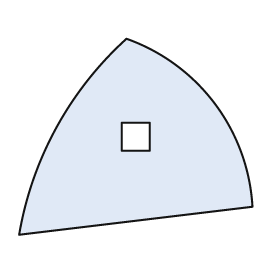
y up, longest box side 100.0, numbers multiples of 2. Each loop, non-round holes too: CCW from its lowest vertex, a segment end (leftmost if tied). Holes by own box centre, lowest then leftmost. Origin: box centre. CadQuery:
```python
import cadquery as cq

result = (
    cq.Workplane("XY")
    .moveTo(-50.0, -42.0)
    .lineTo(50.0, -30.0)
    .threePointArc((34.0, 14.0), (-4.0, 42.0))
    .threePointArc((-34.0, 4.0), (-50.0, -42.0))
    .close()
    .moveTo(-6.0, -6.0)
    .lineTo(6.0, -6.0)
    .lineTo(6.0, 6.0)
    .lineTo(-6.0, 6.0)
    .close()
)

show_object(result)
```